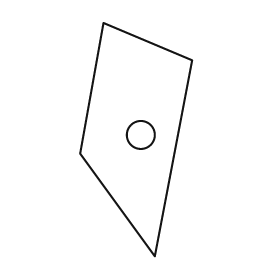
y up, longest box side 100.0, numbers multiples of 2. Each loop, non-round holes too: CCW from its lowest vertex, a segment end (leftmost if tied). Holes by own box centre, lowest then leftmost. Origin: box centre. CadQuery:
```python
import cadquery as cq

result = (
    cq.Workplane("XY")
    .moveTo(8.0, -50.0)
    .lineTo(24.0, 34.0)
    .lineTo(-14.0, 50.0)
    .lineTo(-24.0, -6.0)
    .close()
    .moveTo(2.0, 2.0)
    .circle(6.0)
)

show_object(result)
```